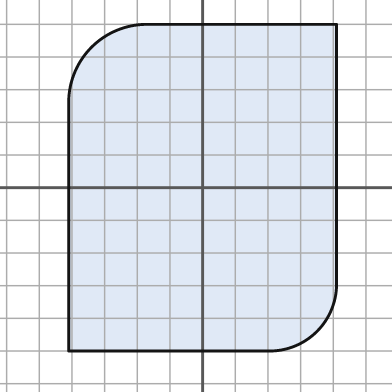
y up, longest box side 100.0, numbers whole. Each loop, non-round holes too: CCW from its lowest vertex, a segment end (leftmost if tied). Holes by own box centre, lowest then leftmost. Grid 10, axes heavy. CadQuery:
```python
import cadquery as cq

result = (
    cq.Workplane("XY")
    .moveTo(-41.0, -50.0)
    .lineTo(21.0, -50.0)
    .threePointArc((35.0, -44.0), (41.0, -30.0))
    .lineTo(41.0, 50.0)
    .lineTo(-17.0, 50.0)
    .threePointArc((-34.0, 43.0), (-41.0, 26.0))
    .close()
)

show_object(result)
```